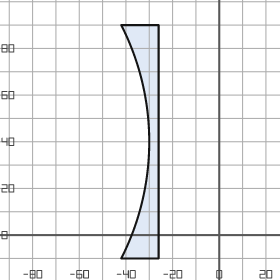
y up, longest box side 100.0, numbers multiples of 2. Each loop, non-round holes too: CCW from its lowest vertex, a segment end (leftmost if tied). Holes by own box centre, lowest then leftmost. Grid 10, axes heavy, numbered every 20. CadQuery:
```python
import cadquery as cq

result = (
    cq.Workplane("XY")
    .moveTo(-42.0, -10.0)
    .lineTo(-26.0, -10.0)
    .lineTo(-26.0, 90.0)
    .lineTo(-42.0, 90.0)
    .threePointArc((-30.0, 40.0), (-42.0, -10.0))
    .close()
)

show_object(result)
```